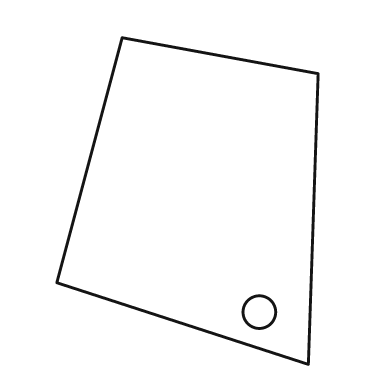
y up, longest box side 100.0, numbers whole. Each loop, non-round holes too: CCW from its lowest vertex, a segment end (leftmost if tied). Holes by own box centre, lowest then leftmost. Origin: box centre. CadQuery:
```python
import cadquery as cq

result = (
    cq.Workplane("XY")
    .moveTo(37.0, -50.0)
    .lineTo(40.0, 39.0)
    .lineTo(-20.0, 50.0)
    .lineTo(-40.0, -25.0)
    .close()
    .moveTo(22.0, -34.0)
    .circle(5.0)
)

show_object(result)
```